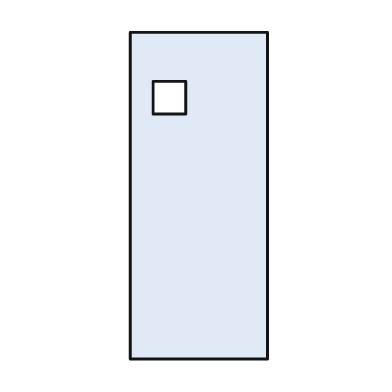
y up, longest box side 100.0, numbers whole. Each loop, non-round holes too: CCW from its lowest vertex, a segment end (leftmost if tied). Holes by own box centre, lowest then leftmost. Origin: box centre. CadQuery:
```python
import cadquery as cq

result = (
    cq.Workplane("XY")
    .moveTo(-21.0, -50.0)
    .lineTo(21.0, -50.0)
    .lineTo(21.0, 50.0)
    .lineTo(-21.0, 50.0)
    .close()
    .moveTo(-14.0, 25.0)
    .lineTo(-4.0, 25.0)
    .lineTo(-4.0, 35.0)
    .lineTo(-14.0, 35.0)
    .close()
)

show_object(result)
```